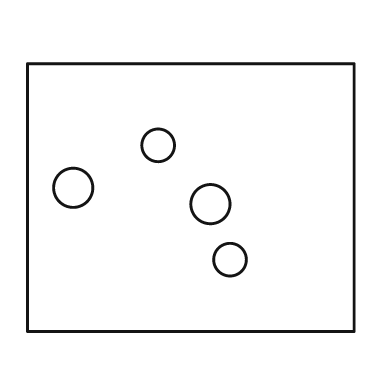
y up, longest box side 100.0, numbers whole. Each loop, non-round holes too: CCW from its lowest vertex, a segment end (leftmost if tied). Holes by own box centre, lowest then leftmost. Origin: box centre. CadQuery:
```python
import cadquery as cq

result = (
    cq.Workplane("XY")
    .moveTo(-50.0, -41.0)
    .lineTo(50.0, -41.0)
    .lineTo(50.0, 41.0)
    .lineTo(-50.0, 41.0)
    .close()
    .moveTo(12.0, -19.0)
    .circle(5.0)
    .moveTo(6.0, -2.0)
    .circle(6.0)
    .moveTo(-36.0, 3.0)
    .circle(6.0)
    .moveTo(-10.0, 16.0)
    .circle(5.0)
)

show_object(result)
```